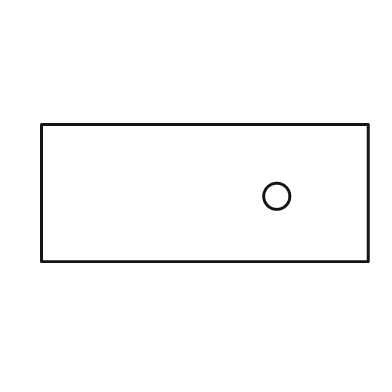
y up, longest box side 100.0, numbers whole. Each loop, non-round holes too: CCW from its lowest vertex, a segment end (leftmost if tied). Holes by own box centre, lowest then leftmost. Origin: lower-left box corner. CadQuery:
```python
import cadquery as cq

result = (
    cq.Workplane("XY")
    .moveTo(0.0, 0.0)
    .lineTo(100.0, 0.0)
    .lineTo(100.0, 42.0)
    .lineTo(0.0, 42.0)
    .close()
    .moveTo(72.0, 20.0)
    .circle(4.0)
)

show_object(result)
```